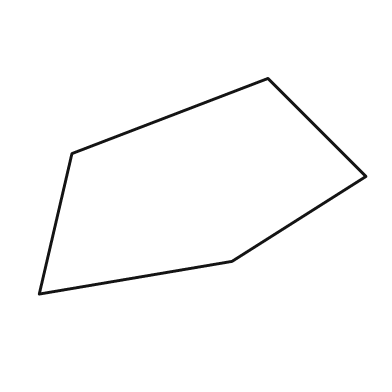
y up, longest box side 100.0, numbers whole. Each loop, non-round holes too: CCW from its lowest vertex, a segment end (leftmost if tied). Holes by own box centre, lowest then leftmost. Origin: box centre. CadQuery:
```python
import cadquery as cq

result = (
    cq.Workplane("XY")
    .moveTo(-50.0, -33.0)
    .lineTo(9.0, -23.0)
    .lineTo(50.0, 3.0)
    .lineTo(20.0, 33.0)
    .lineTo(-40.0, 10.0)
    .close()
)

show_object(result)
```